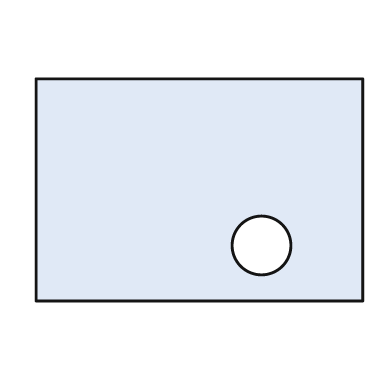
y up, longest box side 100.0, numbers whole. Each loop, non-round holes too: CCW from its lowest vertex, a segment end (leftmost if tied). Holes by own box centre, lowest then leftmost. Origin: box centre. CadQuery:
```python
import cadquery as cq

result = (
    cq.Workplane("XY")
    .moveTo(-50.0, -34.0)
    .lineTo(50.0, -34.0)
    .lineTo(50.0, 34.0)
    .lineTo(-50.0, 34.0)
    .close()
    .moveTo(19.0, -17.0)
    .circle(9.0)
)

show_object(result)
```